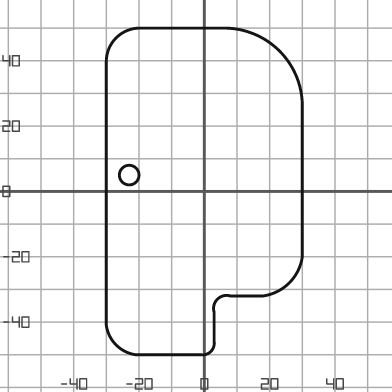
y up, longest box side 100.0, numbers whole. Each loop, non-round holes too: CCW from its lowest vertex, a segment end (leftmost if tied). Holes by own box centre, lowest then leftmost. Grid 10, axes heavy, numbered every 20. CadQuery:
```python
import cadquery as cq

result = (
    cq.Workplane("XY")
    .moveTo(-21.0, -50.0)
    .lineTo(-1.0, -50.0)
    .threePointArc((2.0, -49.0), (3.0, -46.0))
    .lineTo(3.0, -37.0)
    .threePointArc((4.0, -33.0), (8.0, -32.0))
    .lineTo(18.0, -32.0)
    .threePointArc((26.0, -28.0), (30.0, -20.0))
    .lineTo(30.0, 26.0)
    .threePointArc((23.0, 43.0), (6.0, 50.0))
    .lineTo(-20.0, 50.0)
    .threePointArc((-27.0, 47.0), (-30.0, 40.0))
    .lineTo(-30.0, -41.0)
    .threePointArc((-27.0, -47.0), (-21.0, -50.0))
    .close()
    .moveTo(-23.0, 5.0)
    .circle(3.0)
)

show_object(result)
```